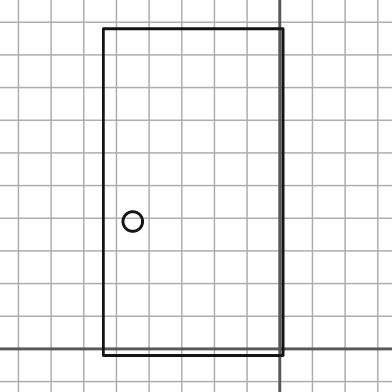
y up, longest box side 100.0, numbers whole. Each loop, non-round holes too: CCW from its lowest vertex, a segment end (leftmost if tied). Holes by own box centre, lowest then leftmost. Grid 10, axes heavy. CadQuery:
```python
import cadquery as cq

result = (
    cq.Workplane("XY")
    .moveTo(-54.0, -2.0)
    .lineTo(1.0, -2.0)
    .lineTo(1.0, 98.0)
    .lineTo(-54.0, 98.0)
    .close()
    .moveTo(-45.0, 39.0)
    .circle(3.0)
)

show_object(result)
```